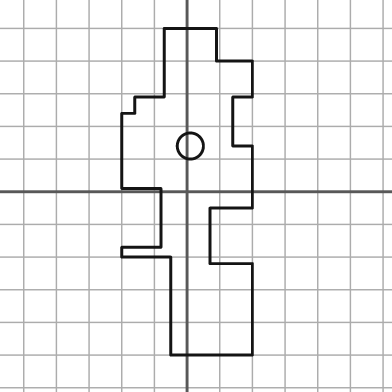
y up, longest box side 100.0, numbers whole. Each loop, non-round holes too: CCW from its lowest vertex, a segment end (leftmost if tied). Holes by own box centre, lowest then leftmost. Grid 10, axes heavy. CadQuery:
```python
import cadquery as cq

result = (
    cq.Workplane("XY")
    .moveTo(-5.0, -50.0)
    .lineTo(20.0, -50.0)
    .lineTo(20.0, -22.0)
    .lineTo(7.0, -22.0)
    .lineTo(7.0, -5.0)
    .lineTo(20.0, -5.0)
    .lineTo(20.0, 14.0)
    .lineTo(14.0, 14.0)
    .lineTo(14.0, 29.0)
    .lineTo(20.0, 29.0)
    .lineTo(20.0, 40.0)
    .lineTo(9.0, 40.0)
    .lineTo(9.0, 50.0)
    .lineTo(-7.0, 50.0)
    .lineTo(-7.0, 29.0)
    .lineTo(-16.0, 29.0)
    .lineTo(-16.0, 24.0)
    .lineTo(-20.0, 24.0)
    .lineTo(-20.0, 1.0)
    .lineTo(-8.0, 1.0)
    .lineTo(-8.0, -17.0)
    .lineTo(-20.0, -17.0)
    .lineTo(-20.0, -20.0)
    .lineTo(-5.0, -20.0)
    .close()
    .moveTo(1.0, 14.0)
    .circle(4.0)
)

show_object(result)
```